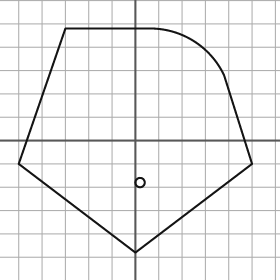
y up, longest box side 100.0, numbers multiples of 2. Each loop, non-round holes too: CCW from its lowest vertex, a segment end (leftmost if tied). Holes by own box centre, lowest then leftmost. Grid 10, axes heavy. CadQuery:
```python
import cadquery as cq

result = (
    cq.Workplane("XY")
    .moveTo(0.0, -48.0)
    .lineTo(50.0, -10.0)
    .lineTo(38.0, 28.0)
    .threePointArc((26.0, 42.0), (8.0, 48.0))
    .lineTo(-30.0, 48.0)
    .lineTo(-50.0, -10.0)
    .close()
    .moveTo(2.0, -18.0)
    .circle(2.0)
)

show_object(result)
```